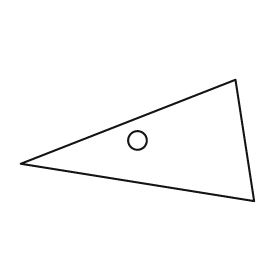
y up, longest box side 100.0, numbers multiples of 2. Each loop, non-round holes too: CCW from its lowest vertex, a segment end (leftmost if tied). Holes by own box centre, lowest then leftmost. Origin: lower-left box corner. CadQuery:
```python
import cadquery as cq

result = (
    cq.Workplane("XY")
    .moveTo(100.0, 0.0)
    .lineTo(92.0, 52.0)
    .lineTo(0.0, 16.0)
    .close()
    .moveTo(50.0, 26.0)
    .circle(4.0)
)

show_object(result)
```